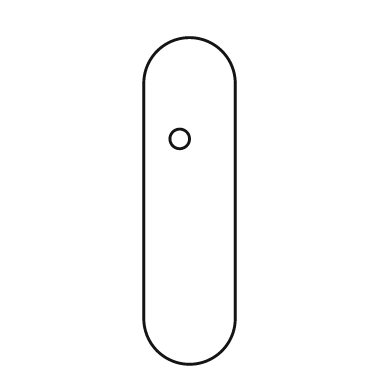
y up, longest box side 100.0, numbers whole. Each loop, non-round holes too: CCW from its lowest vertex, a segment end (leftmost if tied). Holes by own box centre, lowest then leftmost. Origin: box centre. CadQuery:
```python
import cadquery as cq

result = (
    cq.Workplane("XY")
    .moveTo(-14.0, -36.0)
    .threePointArc((0.0, -50.0), (14.0, -36.0))
    .lineTo(14.0, 36.0)
    .threePointArc((0.0, 50.0), (-14.0, 36.0))
    .close()
    .moveTo(-3.0, 19.0)
    .circle(3.0)
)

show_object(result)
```